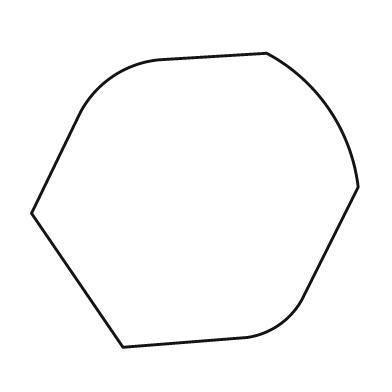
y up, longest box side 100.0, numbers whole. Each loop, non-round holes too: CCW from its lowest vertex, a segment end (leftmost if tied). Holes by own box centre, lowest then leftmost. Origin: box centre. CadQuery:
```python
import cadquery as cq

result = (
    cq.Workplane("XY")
    .moveTo(-22.0, -45.0)
    .lineTo(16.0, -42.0)
    .threePointArc((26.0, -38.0), (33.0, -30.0))
    .lineTo(50.0, 4.0)
    .threePointArc((41.0, 28.0), (22.0, 45.0))
    .lineTo(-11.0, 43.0)
    .threePointArc((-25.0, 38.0), (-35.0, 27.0))
    .lineTo(-50.0, -4.0)
    .close()
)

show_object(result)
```